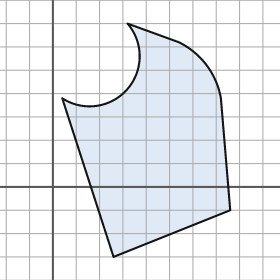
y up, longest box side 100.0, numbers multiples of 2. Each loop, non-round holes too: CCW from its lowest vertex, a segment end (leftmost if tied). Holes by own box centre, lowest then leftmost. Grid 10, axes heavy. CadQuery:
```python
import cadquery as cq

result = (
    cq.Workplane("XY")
    .moveTo(26.0, -30.0)
    .lineTo(76.0, -10.0)
    .lineTo(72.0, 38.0)
    .threePointArc((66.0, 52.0), (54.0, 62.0))
    .lineTo(32.0, 70.0)
    .threePointArc((32.0, 42.0), (4.0, 38.0))
    .close()
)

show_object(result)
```